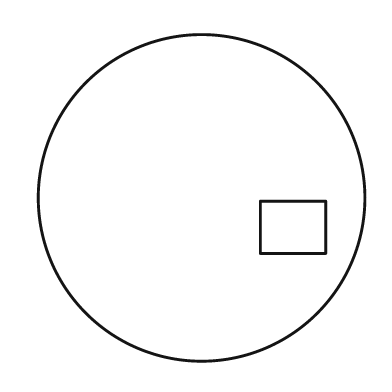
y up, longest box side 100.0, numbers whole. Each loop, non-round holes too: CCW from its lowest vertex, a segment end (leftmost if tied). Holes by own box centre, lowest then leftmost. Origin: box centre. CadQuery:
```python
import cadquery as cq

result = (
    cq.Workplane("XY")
    .moveTo(0.0, 0.0)
    .circle(50.0)
    .moveTo(18.0, -17.0)
    .lineTo(38.0, -17.0)
    .lineTo(38.0, -1.0)
    .lineTo(18.0, -1.0)
    .close()
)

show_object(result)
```